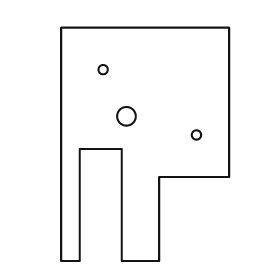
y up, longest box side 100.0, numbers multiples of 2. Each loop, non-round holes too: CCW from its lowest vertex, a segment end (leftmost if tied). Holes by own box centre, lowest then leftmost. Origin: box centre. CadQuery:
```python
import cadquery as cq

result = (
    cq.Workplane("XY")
    .moveTo(-36.0, -50.0)
    .lineTo(-28.0, -50.0)
    .lineTo(-28.0, -2.0)
    .lineTo(-10.0, -2.0)
    .lineTo(-10.0, -50.0)
    .lineTo(6.0, -50.0)
    .lineTo(6.0, -14.0)
    .lineTo(36.0, -14.0)
    .lineTo(36.0, 50.0)
    .lineTo(-36.0, 50.0)
    .close()
    .moveTo(22.0, 4.0)
    .circle(2.0)
    .moveTo(-8.0, 12.0)
    .circle(4.0)
    .moveTo(-18.0, 32.0)
    .circle(2.0)
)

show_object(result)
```